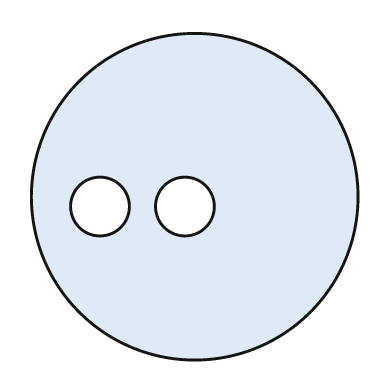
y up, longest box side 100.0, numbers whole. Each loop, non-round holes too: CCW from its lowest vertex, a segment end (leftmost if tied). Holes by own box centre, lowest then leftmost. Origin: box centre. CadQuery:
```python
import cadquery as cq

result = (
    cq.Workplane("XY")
    .moveTo(0.0, 0.0)
    .circle(50.0)
    .moveTo(-29.0, -3.0)
    .circle(9.0)
    .moveTo(-3.0, -3.0)
    .circle(9.0)
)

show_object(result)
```